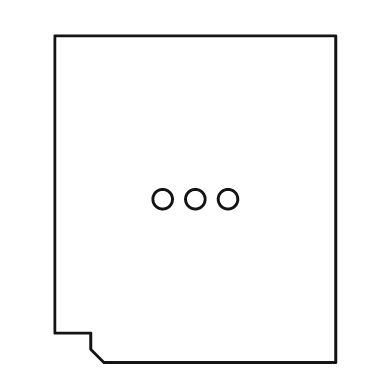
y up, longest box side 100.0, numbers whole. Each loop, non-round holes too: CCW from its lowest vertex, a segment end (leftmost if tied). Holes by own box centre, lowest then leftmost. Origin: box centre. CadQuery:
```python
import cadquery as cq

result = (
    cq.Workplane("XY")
    .moveTo(-28.0, -50.0)
    .lineTo(43.0, -50.0)
    .lineTo(43.0, 50.0)
    .lineTo(-43.0, 50.0)
    .lineTo(-43.0, -41.0)
    .lineTo(-32.0, -41.0)
    .lineTo(-32.0, -46.0)
    .close()
    .moveTo(-10.0, 0.0)
    .circle(3.0)
    .moveTo(0.0, 0.0)
    .circle(3.0)
    .moveTo(10.0, 0.0)
    .circle(3.0)
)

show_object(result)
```